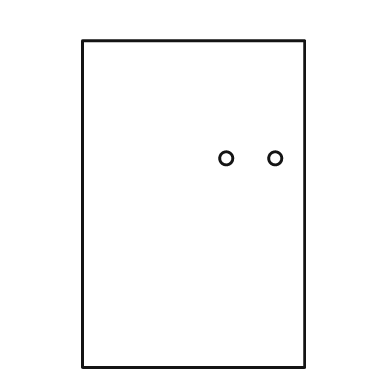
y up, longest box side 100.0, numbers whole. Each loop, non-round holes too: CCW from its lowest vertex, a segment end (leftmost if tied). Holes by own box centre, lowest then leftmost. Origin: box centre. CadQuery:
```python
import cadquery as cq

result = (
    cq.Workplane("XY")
    .moveTo(-34.0, -50.0)
    .lineTo(34.0, -50.0)
    .lineTo(34.0, 50.0)
    .lineTo(-34.0, 50.0)
    .close()
    .moveTo(10.0, 14.0)
    .circle(2.0)
    .moveTo(25.0, 14.0)
    .circle(2.0)
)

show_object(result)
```